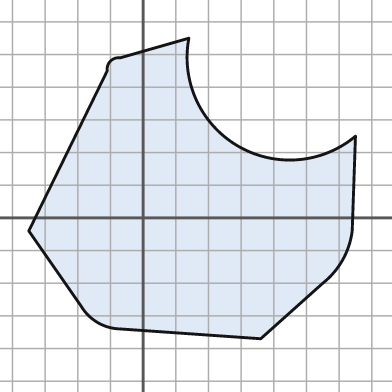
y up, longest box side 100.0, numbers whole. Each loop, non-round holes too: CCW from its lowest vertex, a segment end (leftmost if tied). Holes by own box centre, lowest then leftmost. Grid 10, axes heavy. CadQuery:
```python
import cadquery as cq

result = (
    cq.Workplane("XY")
    .moveTo(36.0, -37.0)
    .lineTo(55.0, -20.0)
    .threePointArc((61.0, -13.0), (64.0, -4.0))
    .lineTo(65.0, 25.0)
    .threePointArc((29.0, 22.0), (14.0, 55.0))
    .lineTo(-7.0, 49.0)
    .threePointArc((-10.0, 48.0), (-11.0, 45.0))
    .lineTo(-35.0, -4.0)
    .lineTo(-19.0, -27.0)
    .threePointArc((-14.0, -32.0), (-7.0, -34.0))
    .close()
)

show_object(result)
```